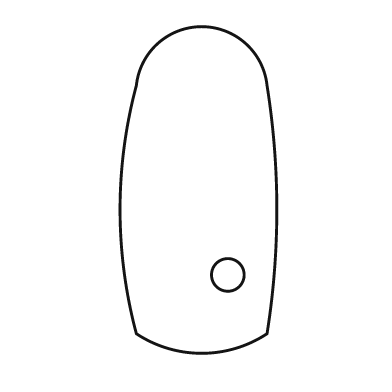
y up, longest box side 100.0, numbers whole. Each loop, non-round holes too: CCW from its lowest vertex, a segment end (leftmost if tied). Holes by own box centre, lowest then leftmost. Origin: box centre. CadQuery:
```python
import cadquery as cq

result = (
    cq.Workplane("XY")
    .moveTo(-19.0, -44.0)
    .threePointArc((1.0, -50.0), (21.0, -44.0))
    .threePointArc((24.0, -6.0), (21.0, 32.0))
    .threePointArc((1.0, 50.0), (-19.0, 32.0))
    .threePointArc((-24.0, -6.0), (-19.0, -44.0))
    .close()
    .moveTo(9.0, -26.0)
    .circle(5.0)
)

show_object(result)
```